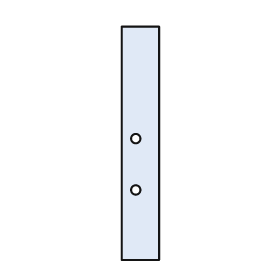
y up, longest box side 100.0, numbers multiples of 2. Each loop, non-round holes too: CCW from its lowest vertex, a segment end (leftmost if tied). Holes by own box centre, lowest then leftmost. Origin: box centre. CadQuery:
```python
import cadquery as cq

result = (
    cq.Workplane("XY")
    .moveTo(-8.0, -50.0)
    .lineTo(8.0, -50.0)
    .lineTo(8.0, 50.0)
    .lineTo(-8.0, 50.0)
    .close()
    .moveTo(-2.0, -20.0)
    .circle(2.0)
    .moveTo(-2.0, 2.0)
    .circle(2.0)
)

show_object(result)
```